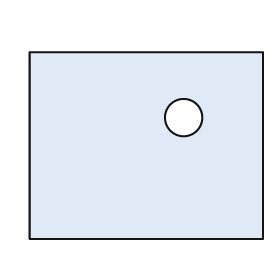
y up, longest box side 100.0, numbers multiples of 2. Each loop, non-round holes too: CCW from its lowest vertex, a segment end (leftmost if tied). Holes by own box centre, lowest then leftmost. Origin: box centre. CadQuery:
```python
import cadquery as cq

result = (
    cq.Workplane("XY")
    .moveTo(-50.0, -40.0)
    .lineTo(50.0, -40.0)
    .lineTo(50.0, 40.0)
    .lineTo(-50.0, 40.0)
    .close()
    .moveTo(16.0, 12.0)
    .circle(8.0)
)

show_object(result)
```